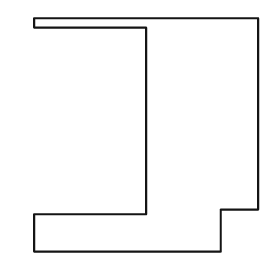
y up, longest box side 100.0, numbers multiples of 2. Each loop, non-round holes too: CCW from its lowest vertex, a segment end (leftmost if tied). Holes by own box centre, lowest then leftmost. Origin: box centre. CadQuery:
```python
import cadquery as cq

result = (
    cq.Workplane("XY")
    .moveTo(-48.0, -50.0)
    .lineTo(32.0, -50.0)
    .lineTo(32.0, -32.0)
    .lineTo(48.0, -32.0)
    .lineTo(48.0, 50.0)
    .lineTo(-48.0, 50.0)
    .lineTo(-48.0, 46.0)
    .lineTo(0.0, 46.0)
    .lineTo(0.0, -34.0)
    .lineTo(-48.0, -34.0)
    .close()
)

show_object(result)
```